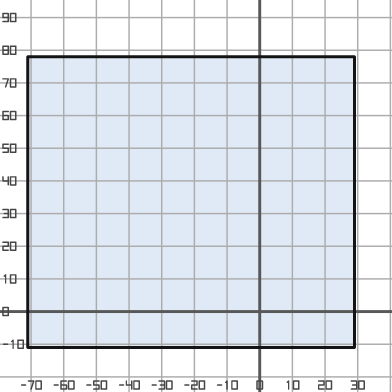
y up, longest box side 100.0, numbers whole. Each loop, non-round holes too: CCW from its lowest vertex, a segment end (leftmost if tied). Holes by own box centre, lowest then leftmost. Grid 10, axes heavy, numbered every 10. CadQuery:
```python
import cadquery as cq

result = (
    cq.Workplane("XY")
    .moveTo(-71.0, -11.0)
    .lineTo(29.0, -11.0)
    .lineTo(29.0, 78.0)
    .lineTo(-71.0, 78.0)
    .close()
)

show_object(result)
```